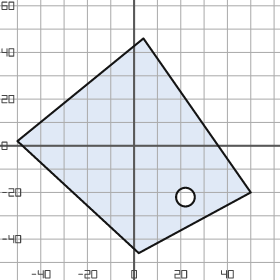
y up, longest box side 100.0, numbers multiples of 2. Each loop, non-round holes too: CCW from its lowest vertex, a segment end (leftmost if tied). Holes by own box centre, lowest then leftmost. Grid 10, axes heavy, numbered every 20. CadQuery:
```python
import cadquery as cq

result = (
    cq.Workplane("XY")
    .moveTo(2.0, -46.0)
    .lineTo(50.0, -20.0)
    .lineTo(4.0, 46.0)
    .lineTo(-50.0, 2.0)
    .close()
    .moveTo(22.0, -22.0)
    .circle(4.0)
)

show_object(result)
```